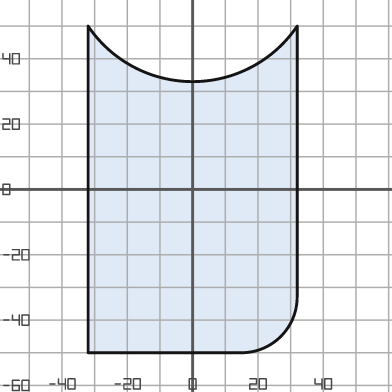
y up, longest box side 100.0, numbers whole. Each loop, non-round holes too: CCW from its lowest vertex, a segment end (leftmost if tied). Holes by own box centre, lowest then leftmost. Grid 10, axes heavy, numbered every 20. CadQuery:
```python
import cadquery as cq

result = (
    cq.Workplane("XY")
    .moveTo(-32.0, -50.0)
    .lineTo(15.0, -50.0)
    .threePointArc((27.0, -45.0), (32.0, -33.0))
    .lineTo(32.0, 50.0)
    .threePointArc((0.0, 33.0), (-32.0, 50.0))
    .close()
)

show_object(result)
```